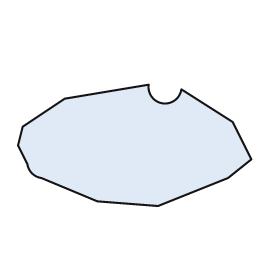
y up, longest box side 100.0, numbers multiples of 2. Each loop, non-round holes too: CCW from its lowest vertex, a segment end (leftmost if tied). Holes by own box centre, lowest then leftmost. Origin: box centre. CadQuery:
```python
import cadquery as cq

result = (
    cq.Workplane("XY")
    .moveTo(10.0, -26.0)
    .lineTo(40.0, -14.0)
    .lineTo(50.0, -6.0)
    .lineTo(42.0, 10.0)
    .lineTo(20.0, 24.0)
    .threePointArc((12.0, 18.0), (6.0, 26.0))
    .lineTo(-30.0, 20.0)
    .lineTo(-48.0, 8.0)
    .lineTo(-50.0, 0.0)
    .lineTo(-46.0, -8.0)
    .threePointArc((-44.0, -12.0), (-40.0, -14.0))
    .lineTo(-16.0, -24.0)
    .close()
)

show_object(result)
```